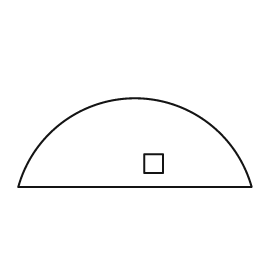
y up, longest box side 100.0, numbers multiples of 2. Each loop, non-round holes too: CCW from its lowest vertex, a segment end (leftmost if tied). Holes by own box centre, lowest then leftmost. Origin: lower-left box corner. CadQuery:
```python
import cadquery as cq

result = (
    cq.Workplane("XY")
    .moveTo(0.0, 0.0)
    .lineTo(100.0, 0.0)
    .threePointArc((50.0, 38.0), (0.0, 0.0))
    .close()
    .moveTo(54.0, 6.0)
    .lineTo(62.0, 6.0)
    .lineTo(62.0, 14.0)
    .lineTo(54.0, 14.0)
    .close()
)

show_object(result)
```